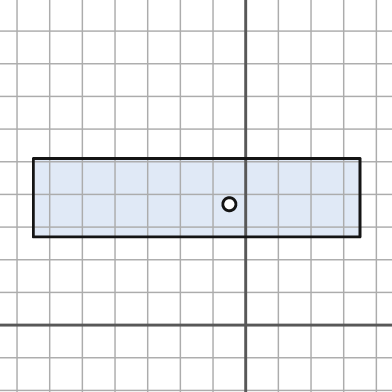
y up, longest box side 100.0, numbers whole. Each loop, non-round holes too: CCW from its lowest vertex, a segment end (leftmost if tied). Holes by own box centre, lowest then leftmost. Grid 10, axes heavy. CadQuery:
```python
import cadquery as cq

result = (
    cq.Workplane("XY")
    .moveTo(-65.0, 27.0)
    .lineTo(35.0, 27.0)
    .lineTo(35.0, 51.0)
    .lineTo(-65.0, 51.0)
    .close()
    .moveTo(-5.0, 37.0)
    .circle(2.0)
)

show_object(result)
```